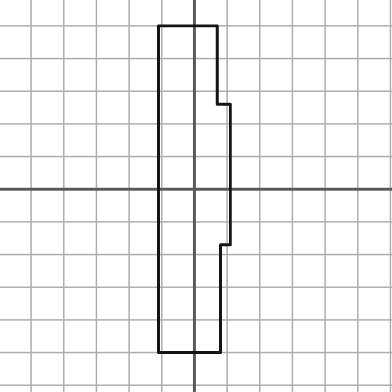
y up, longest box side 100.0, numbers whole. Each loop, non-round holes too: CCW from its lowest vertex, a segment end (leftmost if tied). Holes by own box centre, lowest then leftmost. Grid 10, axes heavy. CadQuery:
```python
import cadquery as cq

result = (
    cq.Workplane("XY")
    .moveTo(-11.0, -50.0)
    .lineTo(8.0, -50.0)
    .lineTo(8.0, -17.0)
    .lineTo(11.0, -17.0)
    .lineTo(11.0, 26.0)
    .lineTo(7.0, 26.0)
    .lineTo(7.0, 50.0)
    .lineTo(-11.0, 50.0)
    .close()
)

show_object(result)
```